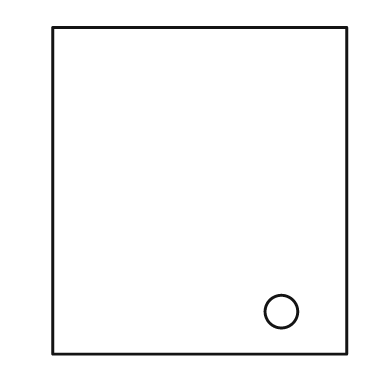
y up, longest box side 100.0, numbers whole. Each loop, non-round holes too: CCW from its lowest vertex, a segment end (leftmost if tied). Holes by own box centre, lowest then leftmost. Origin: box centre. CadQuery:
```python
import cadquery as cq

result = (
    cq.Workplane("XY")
    .moveTo(-45.0, -50.0)
    .lineTo(45.0, -50.0)
    .lineTo(45.0, 50.0)
    .lineTo(-45.0, 50.0)
    .close()
    .moveTo(25.0, -37.0)
    .circle(5.0)
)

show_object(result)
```